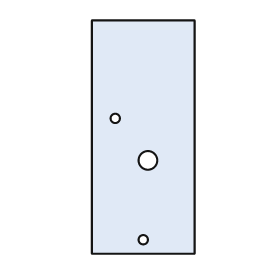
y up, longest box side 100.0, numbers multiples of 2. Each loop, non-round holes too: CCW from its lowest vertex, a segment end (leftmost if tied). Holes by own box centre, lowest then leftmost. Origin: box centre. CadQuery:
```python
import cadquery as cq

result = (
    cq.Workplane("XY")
    .moveTo(-22.0, -50.0)
    .lineTo(22.0, -50.0)
    .lineTo(22.0, 50.0)
    .lineTo(-22.0, 50.0)
    .close()
    .moveTo(0.0, -44.0)
    .circle(2.0)
    .moveTo(2.0, -10.0)
    .circle(4.0)
    .moveTo(-12.0, 8.0)
    .circle(2.0)
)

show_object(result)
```